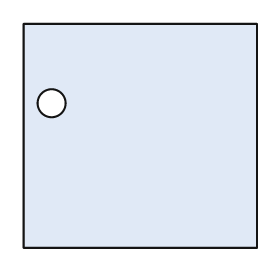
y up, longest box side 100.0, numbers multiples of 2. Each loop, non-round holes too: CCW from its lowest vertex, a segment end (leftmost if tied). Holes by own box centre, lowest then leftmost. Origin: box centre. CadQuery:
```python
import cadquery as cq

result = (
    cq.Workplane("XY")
    .moveTo(-50.0, -48.0)
    .lineTo(50.0, -48.0)
    .lineTo(50.0, 48.0)
    .lineTo(-50.0, 48.0)
    .close()
    .moveTo(-38.0, 14.0)
    .circle(6.0)
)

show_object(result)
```